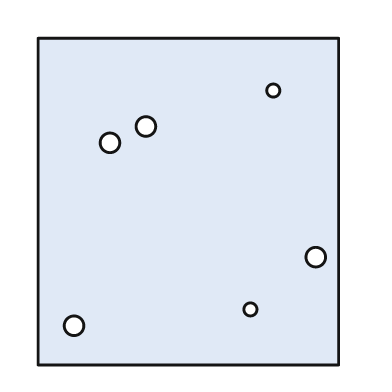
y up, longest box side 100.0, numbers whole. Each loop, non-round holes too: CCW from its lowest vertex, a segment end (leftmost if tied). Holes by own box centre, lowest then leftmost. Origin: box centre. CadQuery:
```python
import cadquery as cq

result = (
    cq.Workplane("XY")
    .moveTo(-46.0, -50.0)
    .lineTo(46.0, -50.0)
    .lineTo(46.0, 50.0)
    .lineTo(-46.0, 50.0)
    .close()
    .moveTo(-35.0, -38.0)
    .circle(3.0)
    .moveTo(19.0, -33.0)
    .circle(2.0)
    .moveTo(39.0, -17.0)
    .circle(3.0)
    .moveTo(-24.0, 18.0)
    .circle(3.0)
    .moveTo(-13.0, 23.0)
    .circle(3.0)
    .moveTo(26.0, 34.0)
    .circle(2.0)
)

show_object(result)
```